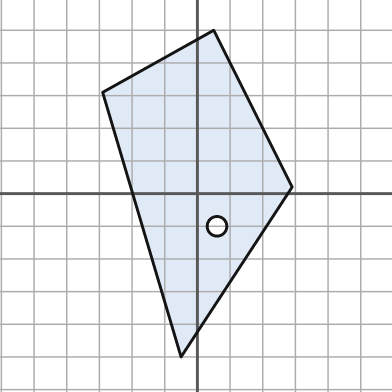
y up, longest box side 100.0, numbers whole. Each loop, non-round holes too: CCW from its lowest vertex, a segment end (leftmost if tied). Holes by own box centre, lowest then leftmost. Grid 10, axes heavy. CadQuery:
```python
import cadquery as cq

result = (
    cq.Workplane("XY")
    .moveTo(-5.0, -50.0)
    .lineTo(29.0, 2.0)
    .lineTo(5.0, 50.0)
    .lineTo(-29.0, 31.0)
    .close()
    .moveTo(6.0, -10.0)
    .circle(3.0)
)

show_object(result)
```